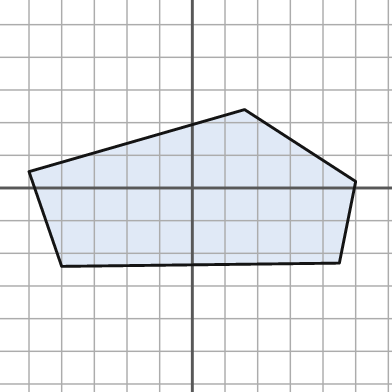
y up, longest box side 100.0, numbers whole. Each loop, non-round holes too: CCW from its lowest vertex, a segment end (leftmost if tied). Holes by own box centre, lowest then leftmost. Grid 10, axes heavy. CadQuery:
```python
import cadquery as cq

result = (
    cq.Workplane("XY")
    .moveTo(-40.0, -24.0)
    .lineTo(45.0, -23.0)
    .lineTo(50.0, 2.0)
    .lineTo(16.0, 24.0)
    .lineTo(-50.0, 5.0)
    .close()
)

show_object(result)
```